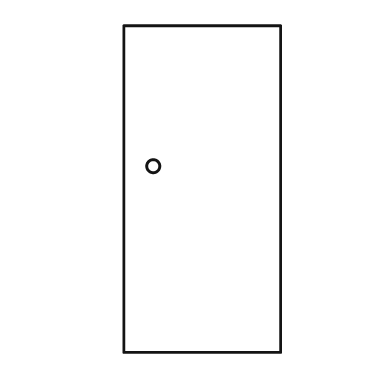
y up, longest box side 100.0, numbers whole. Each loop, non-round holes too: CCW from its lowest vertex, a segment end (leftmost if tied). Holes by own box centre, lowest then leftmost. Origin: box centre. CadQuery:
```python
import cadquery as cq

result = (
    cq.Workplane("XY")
    .moveTo(-24.0, -50.0)
    .lineTo(24.0, -50.0)
    .lineTo(24.0, 50.0)
    .lineTo(-24.0, 50.0)
    .close()
    .moveTo(-15.0, 7.0)
    .circle(2.0)
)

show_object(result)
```